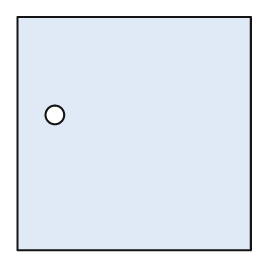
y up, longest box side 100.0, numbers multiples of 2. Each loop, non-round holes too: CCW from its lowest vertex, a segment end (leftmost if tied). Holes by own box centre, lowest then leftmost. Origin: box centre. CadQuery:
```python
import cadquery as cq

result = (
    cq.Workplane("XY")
    .moveTo(-50.0, -50.0)
    .lineTo(50.0, -50.0)
    .lineTo(50.0, 50.0)
    .lineTo(-50.0, 50.0)
    .close()
    .moveTo(-34.0, 8.0)
    .circle(4.0)
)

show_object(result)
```